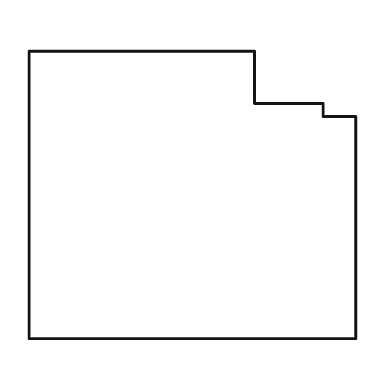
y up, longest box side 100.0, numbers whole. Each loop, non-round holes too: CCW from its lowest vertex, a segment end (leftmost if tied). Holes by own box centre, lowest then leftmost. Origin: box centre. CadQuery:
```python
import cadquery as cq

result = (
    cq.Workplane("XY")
    .moveTo(-50.0, -44.0)
    .lineTo(50.0, -44.0)
    .lineTo(50.0, 24.0)
    .lineTo(40.0, 24.0)
    .lineTo(40.0, 28.0)
    .lineTo(19.0, 28.0)
    .lineTo(19.0, 44.0)
    .lineTo(-50.0, 44.0)
    .close()
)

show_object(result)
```